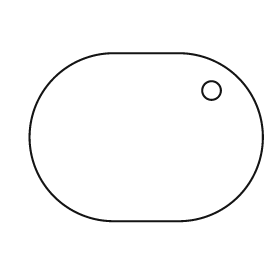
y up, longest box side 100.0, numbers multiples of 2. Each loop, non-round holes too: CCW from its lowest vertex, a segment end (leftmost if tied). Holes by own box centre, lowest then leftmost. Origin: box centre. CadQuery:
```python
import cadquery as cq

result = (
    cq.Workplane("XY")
    .moveTo(-14.0, -36.0)
    .lineTo(14.0, -36.0)
    .threePointArc((50.0, 0.0), (14.0, 36.0))
    .lineTo(-14.0, 36.0)
    .threePointArc((-50.0, 0.0), (-14.0, -36.0))
    .close()
    .moveTo(28.0, 20.0)
    .circle(4.0)
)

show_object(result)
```